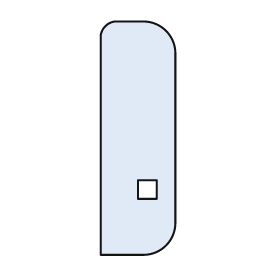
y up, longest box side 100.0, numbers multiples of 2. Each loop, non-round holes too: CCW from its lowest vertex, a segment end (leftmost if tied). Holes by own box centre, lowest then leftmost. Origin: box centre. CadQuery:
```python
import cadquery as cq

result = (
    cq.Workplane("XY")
    .moveTo(-16.0, -50.0)
    .lineTo(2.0, -50.0)
    .threePointArc((12.0, -46.0), (16.0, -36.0))
    .lineTo(16.0, 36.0)
    .threePointArc((12.0, 46.0), (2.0, 50.0))
    .lineTo(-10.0, 50.0)
    .threePointArc((-14.0, 48.0), (-16.0, 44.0))
    .close()
    .moveTo(0.0, -26.0)
    .lineTo(8.0, -26.0)
    .lineTo(8.0, -18.0)
    .lineTo(0.0, -18.0)
    .close()
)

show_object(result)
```